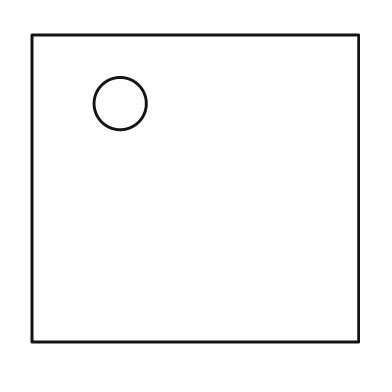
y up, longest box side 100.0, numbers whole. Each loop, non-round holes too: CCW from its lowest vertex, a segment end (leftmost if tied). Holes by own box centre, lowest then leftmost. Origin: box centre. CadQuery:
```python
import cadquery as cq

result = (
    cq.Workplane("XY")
    .moveTo(-50.0, -47.0)
    .lineTo(50.0, -47.0)
    .lineTo(50.0, 47.0)
    .lineTo(-50.0, 47.0)
    .close()
    .moveTo(-23.0, 26.0)
    .circle(8.0)
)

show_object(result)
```